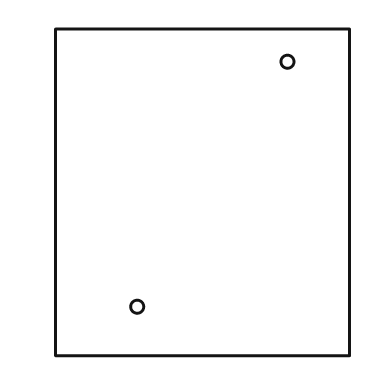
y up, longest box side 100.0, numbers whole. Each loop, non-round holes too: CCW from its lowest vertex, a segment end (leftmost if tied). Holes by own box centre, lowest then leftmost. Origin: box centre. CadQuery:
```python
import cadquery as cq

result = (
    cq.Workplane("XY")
    .moveTo(-45.0, -50.0)
    .lineTo(45.0, -50.0)
    .lineTo(45.0, 50.0)
    .lineTo(-45.0, 50.0)
    .close()
    .moveTo(-20.0, -35.0)
    .circle(2.0)
    .moveTo(26.0, 40.0)
    .circle(2.0)
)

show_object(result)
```